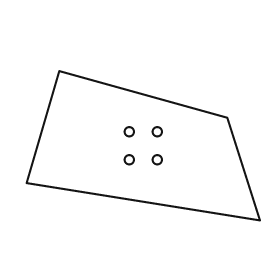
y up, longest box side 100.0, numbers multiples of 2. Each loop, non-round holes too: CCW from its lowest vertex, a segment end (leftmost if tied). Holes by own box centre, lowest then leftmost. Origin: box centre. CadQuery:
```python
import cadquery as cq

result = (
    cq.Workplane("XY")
    .moveTo(50.0, -32.0)
    .lineTo(36.0, 12.0)
    .lineTo(-36.0, 32.0)
    .lineTo(-50.0, -16.0)
    .close()
    .moveTo(-6.0, -6.0)
    .circle(2.0)
    .moveTo(6.0, -6.0)
    .circle(2.0)
    .moveTo(-6.0, 6.0)
    .circle(2.0)
    .moveTo(6.0, 6.0)
    .circle(2.0)
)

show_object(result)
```